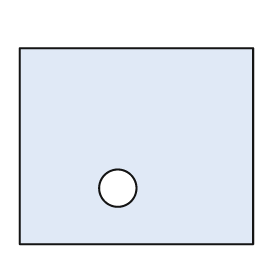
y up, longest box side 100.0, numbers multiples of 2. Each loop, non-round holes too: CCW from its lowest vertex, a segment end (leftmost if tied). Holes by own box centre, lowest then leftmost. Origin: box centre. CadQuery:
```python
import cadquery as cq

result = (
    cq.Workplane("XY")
    .moveTo(-50.0, -42.0)
    .lineTo(50.0, -42.0)
    .lineTo(50.0, 42.0)
    .lineTo(-50.0, 42.0)
    .close()
    .moveTo(-8.0, -18.0)
    .circle(8.0)
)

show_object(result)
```